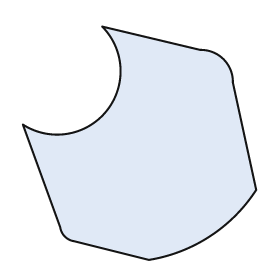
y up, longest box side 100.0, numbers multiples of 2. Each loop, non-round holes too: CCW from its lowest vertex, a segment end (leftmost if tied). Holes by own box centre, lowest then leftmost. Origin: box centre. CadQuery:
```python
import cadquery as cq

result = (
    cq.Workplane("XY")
    .moveTo(4.0, -50.0)
    .threePointArc((30.0, -40.0), (50.0, -20.0))
    .lineTo(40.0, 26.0)
    .threePointArc((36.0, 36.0), (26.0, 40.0))
    .lineTo(-16.0, 50.0)
    .threePointArc((-14.0, 14.0), (-50.0, 8.0))
    .lineTo(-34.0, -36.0)
    .threePointArc((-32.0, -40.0), (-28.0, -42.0))
    .close()
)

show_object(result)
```